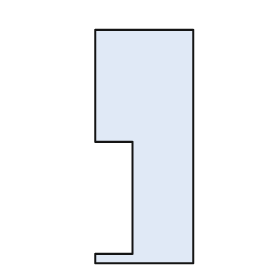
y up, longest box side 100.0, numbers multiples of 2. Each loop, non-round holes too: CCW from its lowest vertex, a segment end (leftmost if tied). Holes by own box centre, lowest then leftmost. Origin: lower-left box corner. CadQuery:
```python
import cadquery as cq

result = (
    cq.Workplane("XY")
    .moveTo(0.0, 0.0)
    .lineTo(42.0, 0.0)
    .lineTo(42.0, 100.0)
    .lineTo(0.0, 100.0)
    .lineTo(0.0, 52.0)
    .lineTo(16.0, 52.0)
    .lineTo(16.0, 4.0)
    .lineTo(0.0, 4.0)
    .close()
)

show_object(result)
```